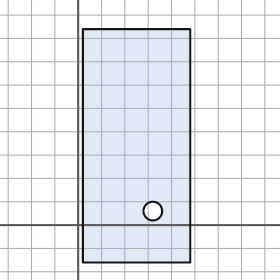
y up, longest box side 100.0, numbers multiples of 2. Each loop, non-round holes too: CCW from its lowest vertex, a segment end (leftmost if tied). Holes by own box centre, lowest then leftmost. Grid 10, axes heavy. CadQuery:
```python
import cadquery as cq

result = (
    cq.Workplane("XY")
    .moveTo(2.0, -16.0)
    .lineTo(48.0, -16.0)
    .lineTo(48.0, 84.0)
    .lineTo(2.0, 84.0)
    .close()
    .moveTo(32.0, 6.0)
    .circle(4.0)
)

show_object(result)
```